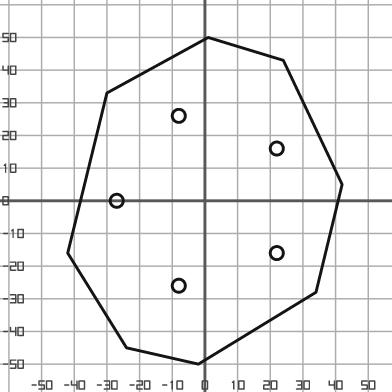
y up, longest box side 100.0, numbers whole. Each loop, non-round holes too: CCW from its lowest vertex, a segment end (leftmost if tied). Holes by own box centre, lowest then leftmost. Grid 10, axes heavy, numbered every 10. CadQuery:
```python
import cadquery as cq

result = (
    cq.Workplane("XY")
    .moveTo(-2.0, -50.0)
    .lineTo(34.0, -28.0)
    .lineTo(42.0, 5.0)
    .lineTo(24.0, 43.0)
    .lineTo(1.0, 50.0)
    .lineTo(-30.0, 33.0)
    .lineTo(-42.0, -16.0)
    .lineTo(-24.0, -45.0)
    .close()
    .moveTo(-8.0, -26.0)
    .circle(2.0)
    .moveTo(22.0, -16.0)
    .circle(2.0)
    .moveTo(-27.0, 0.0)
    .circle(2.0)
    .moveTo(22.0, 16.0)
    .circle(2.0)
    .moveTo(-8.0, 26.0)
    .circle(2.0)
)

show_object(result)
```